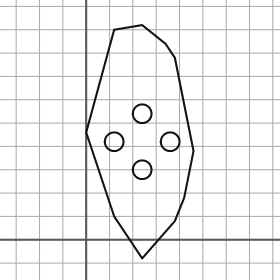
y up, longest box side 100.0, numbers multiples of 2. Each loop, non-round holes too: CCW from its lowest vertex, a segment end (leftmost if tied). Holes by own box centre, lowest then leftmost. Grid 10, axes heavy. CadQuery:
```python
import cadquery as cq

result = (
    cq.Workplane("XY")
    .moveTo(24.0, -8.0)
    .lineTo(38.0, 8.0)
    .lineTo(42.0, 18.0)
    .lineTo(46.0, 38.0)
    .lineTo(38.0, 78.0)
    .lineTo(34.0, 84.0)
    .lineTo(24.0, 92.0)
    .lineTo(12.0, 90.0)
    .lineTo(0.0, 46.0)
    .lineTo(12.0, 10.0)
    .close()
    .moveTo(24.0, 30.0)
    .circle(4.0)
    .moveTo(12.0, 42.0)
    .circle(4.0)
    .moveTo(36.0, 42.0)
    .circle(4.0)
    .moveTo(24.0, 54.0)
    .circle(4.0)
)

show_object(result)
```